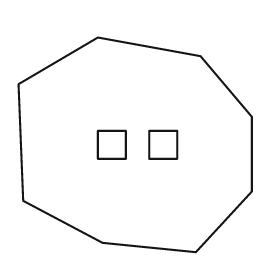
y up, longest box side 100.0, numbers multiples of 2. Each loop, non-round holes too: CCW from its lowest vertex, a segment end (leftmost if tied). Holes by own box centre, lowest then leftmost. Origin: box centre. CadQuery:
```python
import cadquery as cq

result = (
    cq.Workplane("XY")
    .moveTo(26.0, -46.0)
    .lineTo(50.0, -20.0)
    .lineTo(50.0, 12.0)
    .lineTo(28.0, 38.0)
    .lineTo(-16.0, 46.0)
    .lineTo(-50.0, 26.0)
    .lineTo(-48.0, -24.0)
    .lineTo(-14.0, -42.0)
    .close()
    .moveTo(-16.0, -6.0)
    .lineTo(-4.0, -6.0)
    .lineTo(-4.0, 6.0)
    .lineTo(-16.0, 6.0)
    .close()
    .moveTo(6.0, -6.0)
    .lineTo(18.0, -6.0)
    .lineTo(18.0, 6.0)
    .lineTo(6.0, 6.0)
    .close()
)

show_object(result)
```